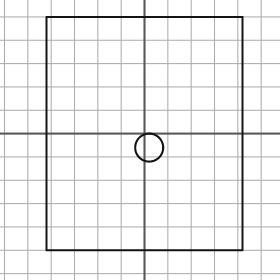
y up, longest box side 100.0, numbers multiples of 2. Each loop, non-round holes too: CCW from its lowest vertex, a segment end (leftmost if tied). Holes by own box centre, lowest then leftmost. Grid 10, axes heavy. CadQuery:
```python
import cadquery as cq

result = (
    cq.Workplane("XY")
    .moveTo(-42.0, -50.0)
    .lineTo(42.0, -50.0)
    .lineTo(42.0, 50.0)
    .lineTo(-42.0, 50.0)
    .close()
    .moveTo(2.0, -6.0)
    .circle(6.0)
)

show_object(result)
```